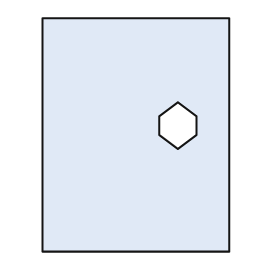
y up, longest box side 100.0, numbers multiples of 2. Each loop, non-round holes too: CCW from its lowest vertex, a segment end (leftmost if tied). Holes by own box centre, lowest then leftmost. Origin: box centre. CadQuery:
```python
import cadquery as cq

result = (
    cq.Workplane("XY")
    .moveTo(-40.0, -50.0)
    .lineTo(40.0, -50.0)
    .lineTo(40.0, 50.0)
    .lineTo(-40.0, 50.0)
    .close()
    .moveTo(18.0, -6.0)
    .lineTo(26.0, 0.0)
    .lineTo(26.0, 8.0)
    .lineTo(18.0, 14.0)
    .lineTo(10.0, 8.0)
    .lineTo(10.0, 0.0)
    .close()
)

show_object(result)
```